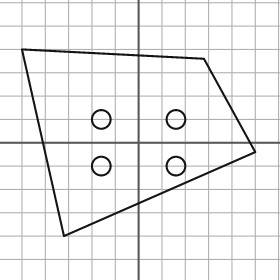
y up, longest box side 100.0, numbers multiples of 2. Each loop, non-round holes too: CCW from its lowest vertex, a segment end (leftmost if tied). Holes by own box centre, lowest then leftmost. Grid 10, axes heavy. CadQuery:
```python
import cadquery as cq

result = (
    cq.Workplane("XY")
    .moveTo(-32.0, -40.0)
    .lineTo(50.0, -4.0)
    .lineTo(28.0, 36.0)
    .lineTo(-50.0, 40.0)
    .close()
    .moveTo(-16.0, -10.0)
    .circle(4.0)
    .moveTo(16.0, -10.0)
    .circle(4.0)
    .moveTo(-16.0, 10.0)
    .circle(4.0)
    .moveTo(16.0, 10.0)
    .circle(4.0)
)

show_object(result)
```